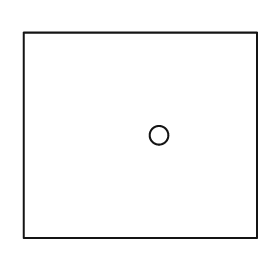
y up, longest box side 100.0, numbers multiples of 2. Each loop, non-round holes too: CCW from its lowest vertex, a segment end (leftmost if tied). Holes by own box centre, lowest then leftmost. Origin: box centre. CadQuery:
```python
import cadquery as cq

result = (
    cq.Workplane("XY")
    .moveTo(-50.0, -44.0)
    .lineTo(50.0, -44.0)
    .lineTo(50.0, 44.0)
    .lineTo(-50.0, 44.0)
    .close()
    .moveTo(8.0, 0.0)
    .circle(4.0)
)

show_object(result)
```